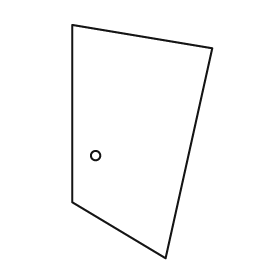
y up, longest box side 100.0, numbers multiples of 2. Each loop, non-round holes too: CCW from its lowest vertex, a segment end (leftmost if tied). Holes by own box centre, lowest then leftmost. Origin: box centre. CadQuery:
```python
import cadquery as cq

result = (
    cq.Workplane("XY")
    .moveTo(10.0, -50.0)
    .lineTo(30.0, 40.0)
    .lineTo(-30.0, 50.0)
    .lineTo(-30.0, -26.0)
    .close()
    .moveTo(-20.0, -6.0)
    .circle(2.0)
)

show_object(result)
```